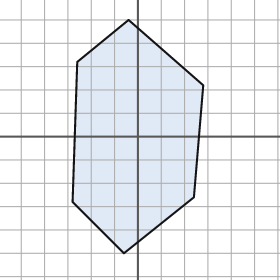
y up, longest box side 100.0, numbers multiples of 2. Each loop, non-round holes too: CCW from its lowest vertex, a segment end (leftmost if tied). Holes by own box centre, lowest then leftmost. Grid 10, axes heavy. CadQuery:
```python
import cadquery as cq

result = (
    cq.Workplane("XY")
    .moveTo(-6.0, -50.0)
    .lineTo(24.0, -26.0)
    .lineTo(28.0, 22.0)
    .lineTo(-4.0, 50.0)
    .lineTo(-26.0, 32.0)
    .lineTo(-28.0, -28.0)
    .close()
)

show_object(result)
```